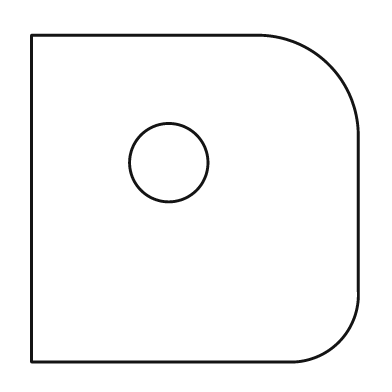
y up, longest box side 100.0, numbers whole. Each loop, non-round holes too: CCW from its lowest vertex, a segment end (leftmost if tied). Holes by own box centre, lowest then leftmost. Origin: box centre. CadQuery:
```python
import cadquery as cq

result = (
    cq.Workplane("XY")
    .moveTo(-50.0, -50.0)
    .lineTo(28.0, -50.0)
    .threePointArc((44.0, -44.0), (50.0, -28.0))
    .lineTo(50.0, 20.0)
    .threePointArc((41.0, 41.0), (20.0, 50.0))
    .lineTo(-50.0, 50.0)
    .close()
    .moveTo(-8.0, 11.0)
    .circle(12.0)
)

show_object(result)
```